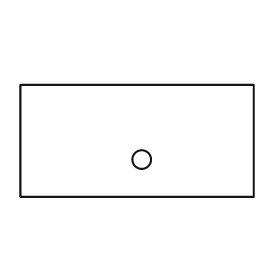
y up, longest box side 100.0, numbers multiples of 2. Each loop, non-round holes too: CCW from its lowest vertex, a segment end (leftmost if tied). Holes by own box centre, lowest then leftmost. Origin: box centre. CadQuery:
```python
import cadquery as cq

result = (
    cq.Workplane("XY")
    .moveTo(-50.0, -24.0)
    .lineTo(50.0, -24.0)
    .lineTo(50.0, 24.0)
    .lineTo(-50.0, 24.0)
    .close()
    .moveTo(2.0, -8.0)
    .circle(4.0)
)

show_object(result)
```